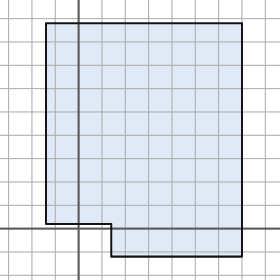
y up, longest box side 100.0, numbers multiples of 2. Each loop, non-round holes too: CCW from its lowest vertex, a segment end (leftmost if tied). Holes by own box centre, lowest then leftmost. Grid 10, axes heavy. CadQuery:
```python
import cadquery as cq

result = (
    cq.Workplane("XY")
    .moveTo(14.0, -12.0)
    .lineTo(70.0, -12.0)
    .lineTo(70.0, 88.0)
    .lineTo(-14.0, 88.0)
    .lineTo(-14.0, 2.0)
    .lineTo(14.0, 2.0)
    .close()
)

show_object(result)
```